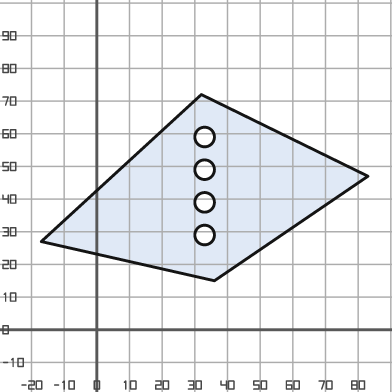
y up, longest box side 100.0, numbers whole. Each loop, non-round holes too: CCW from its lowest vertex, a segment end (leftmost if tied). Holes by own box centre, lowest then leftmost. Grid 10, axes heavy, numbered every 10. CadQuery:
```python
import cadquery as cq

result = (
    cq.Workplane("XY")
    .moveTo(36.0, 15.0)
    .lineTo(83.0, 47.0)
    .lineTo(32.0, 72.0)
    .lineTo(-17.0, 27.0)
    .close()
    .moveTo(33.0, 29.0)
    .circle(3.0)
    .moveTo(33.0, 39.0)
    .circle(3.0)
    .moveTo(33.0, 49.0)
    .circle(3.0)
    .moveTo(33.0, 59.0)
    .circle(3.0)
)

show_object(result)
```